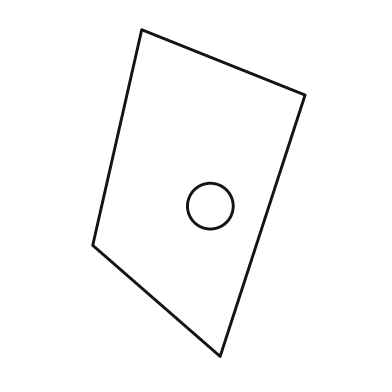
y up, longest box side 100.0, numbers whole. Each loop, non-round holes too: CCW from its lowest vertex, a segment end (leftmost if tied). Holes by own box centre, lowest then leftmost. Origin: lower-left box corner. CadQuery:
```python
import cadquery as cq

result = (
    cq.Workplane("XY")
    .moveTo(39.0, 0.0)
    .lineTo(65.0, 80.0)
    .lineTo(15.0, 100.0)
    .lineTo(0.0, 34.0)
    .close()
    .moveTo(36.0, 46.0)
    .circle(7.0)
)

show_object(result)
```